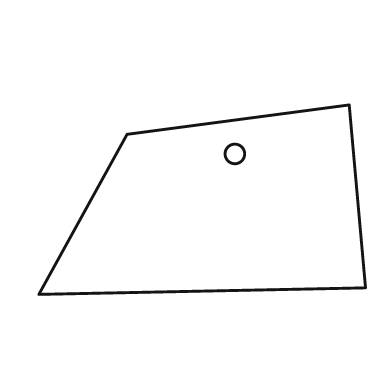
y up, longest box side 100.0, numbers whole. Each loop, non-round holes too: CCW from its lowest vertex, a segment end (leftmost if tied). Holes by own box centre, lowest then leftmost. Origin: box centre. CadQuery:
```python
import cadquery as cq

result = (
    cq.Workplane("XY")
    .moveTo(-50.0, -29.0)
    .lineTo(50.0, -27.0)
    .lineTo(45.0, 29.0)
    .lineTo(-23.0, 20.0)
    .close()
    .moveTo(10.0, 14.0)
    .circle(3.0)
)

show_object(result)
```